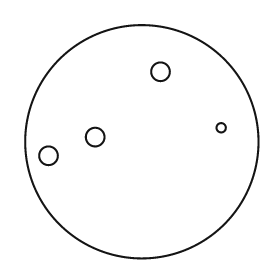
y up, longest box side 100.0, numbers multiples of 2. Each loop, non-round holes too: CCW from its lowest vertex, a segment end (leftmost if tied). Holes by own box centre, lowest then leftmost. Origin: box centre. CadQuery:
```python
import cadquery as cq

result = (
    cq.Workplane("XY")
    .moveTo(0.0, 0.0)
    .circle(50.0)
    .moveTo(-40.0, -6.0)
    .circle(4.0)
    .moveTo(-20.0, 2.0)
    .circle(4.0)
    .moveTo(34.0, 6.0)
    .circle(2.0)
    .moveTo(8.0, 30.0)
    .circle(4.0)
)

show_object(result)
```